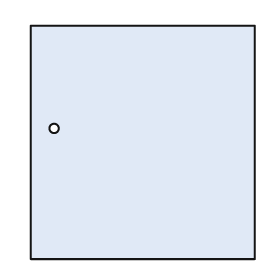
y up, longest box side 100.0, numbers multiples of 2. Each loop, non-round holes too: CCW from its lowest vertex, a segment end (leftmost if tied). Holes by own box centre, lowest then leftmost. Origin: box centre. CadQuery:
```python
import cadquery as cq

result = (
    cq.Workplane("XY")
    .moveTo(-48.0, -50.0)
    .lineTo(48.0, -50.0)
    .lineTo(48.0, 50.0)
    .lineTo(-48.0, 50.0)
    .close()
    .moveTo(-38.0, 6.0)
    .circle(2.0)
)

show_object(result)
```